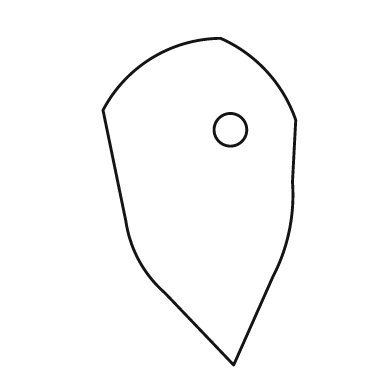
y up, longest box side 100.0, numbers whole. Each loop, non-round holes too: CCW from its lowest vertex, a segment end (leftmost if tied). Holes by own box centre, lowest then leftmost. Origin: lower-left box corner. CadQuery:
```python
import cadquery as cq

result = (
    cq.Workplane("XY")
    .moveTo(40.0, 0.0)
    .lineTo(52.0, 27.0)
    .threePointArc((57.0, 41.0), (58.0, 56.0))
    .lineTo(59.0, 75.0)
    .threePointArc((50.0, 90.0), (36.0, 100.0))
    .threePointArc((15.0, 94.0), (0.0, 78.0))
    .lineTo(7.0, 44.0)
    .threePointArc((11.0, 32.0), (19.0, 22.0))
    .close()
    .moveTo(39.0, 72.0)
    .circle(5.0)
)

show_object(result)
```